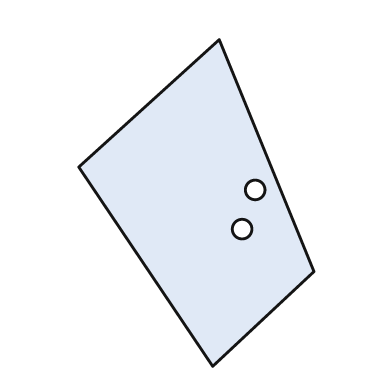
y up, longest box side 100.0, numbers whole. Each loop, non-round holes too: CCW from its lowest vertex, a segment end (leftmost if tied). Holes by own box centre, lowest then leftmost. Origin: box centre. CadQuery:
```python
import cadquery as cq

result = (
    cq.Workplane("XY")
    .moveTo(5.0, -50.0)
    .lineTo(36.0, -21.0)
    .lineTo(7.0, 50.0)
    .lineTo(-36.0, 11.0)
    .close()
    .moveTo(14.0, -8.0)
    .circle(3.0)
    .moveTo(18.0, 4.0)
    .circle(3.0)
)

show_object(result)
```